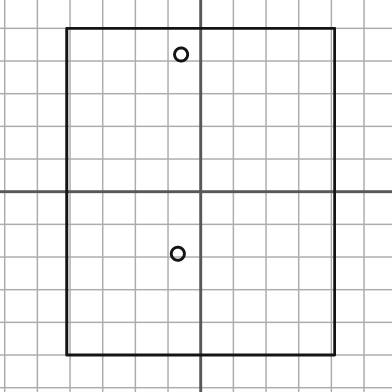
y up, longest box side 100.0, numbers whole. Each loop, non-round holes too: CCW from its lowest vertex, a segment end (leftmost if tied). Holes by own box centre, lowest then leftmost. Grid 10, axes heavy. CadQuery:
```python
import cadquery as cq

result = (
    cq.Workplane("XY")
    .moveTo(-41.0, -50.0)
    .lineTo(41.0, -50.0)
    .lineTo(41.0, 50.0)
    .lineTo(-41.0, 50.0)
    .close()
    .moveTo(-7.0, -19.0)
    .circle(2.0)
    .moveTo(-6.0, 42.0)
    .circle(2.0)
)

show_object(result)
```